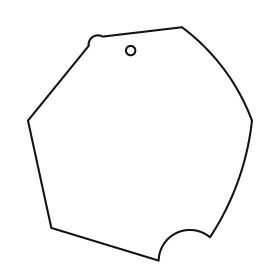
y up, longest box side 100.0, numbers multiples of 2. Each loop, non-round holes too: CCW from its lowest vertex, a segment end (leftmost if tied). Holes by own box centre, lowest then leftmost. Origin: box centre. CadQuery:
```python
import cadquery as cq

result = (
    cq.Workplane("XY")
    .moveTo(8.0, -50.0)
    .threePointArc((16.0, -38.0), (30.0, -40.0))
    .threePointArc((42.0, -16.0), (48.0, 10.0))
    .threePointArc((36.0, 32.0), (18.0, 50.0))
    .lineTo(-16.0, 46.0)
    .threePointArc((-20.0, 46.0), (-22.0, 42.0))
    .lineTo(-48.0, 10.0)
    .lineTo(-38.0, -36.0)
    .close()
    .moveTo(-4.0, 40.0)
    .circle(2.0)
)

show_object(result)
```